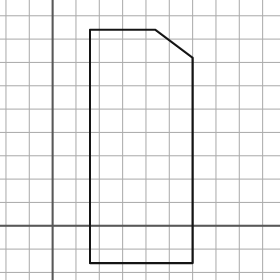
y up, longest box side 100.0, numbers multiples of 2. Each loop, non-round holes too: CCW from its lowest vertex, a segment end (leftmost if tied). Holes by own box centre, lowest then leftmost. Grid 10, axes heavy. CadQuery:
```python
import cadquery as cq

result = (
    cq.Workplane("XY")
    .moveTo(16.0, -16.0)
    .lineTo(60.0, -16.0)
    .lineTo(60.0, 72.0)
    .lineTo(44.0, 84.0)
    .lineTo(16.0, 84.0)
    .close()
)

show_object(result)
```